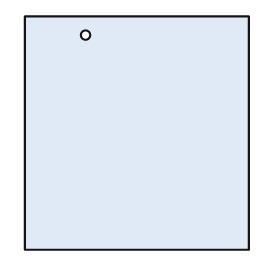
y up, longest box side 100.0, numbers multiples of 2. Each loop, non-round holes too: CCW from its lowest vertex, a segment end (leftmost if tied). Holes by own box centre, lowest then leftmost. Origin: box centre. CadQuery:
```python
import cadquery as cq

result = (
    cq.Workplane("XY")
    .moveTo(-48.0, -50.0)
    .lineTo(48.0, -50.0)
    .lineTo(48.0, 50.0)
    .lineTo(-48.0, 50.0)
    .close()
    .moveTo(-22.0, 42.0)
    .circle(2.0)
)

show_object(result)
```